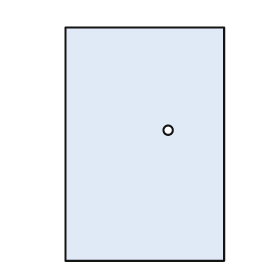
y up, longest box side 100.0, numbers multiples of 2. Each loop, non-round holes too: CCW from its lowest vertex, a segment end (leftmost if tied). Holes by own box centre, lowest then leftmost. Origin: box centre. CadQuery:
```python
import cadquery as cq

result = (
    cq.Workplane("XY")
    .moveTo(-34.0, -50.0)
    .lineTo(34.0, -50.0)
    .lineTo(34.0, 50.0)
    .lineTo(-34.0, 50.0)
    .close()
    .moveTo(10.0, 6.0)
    .circle(2.0)
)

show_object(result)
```